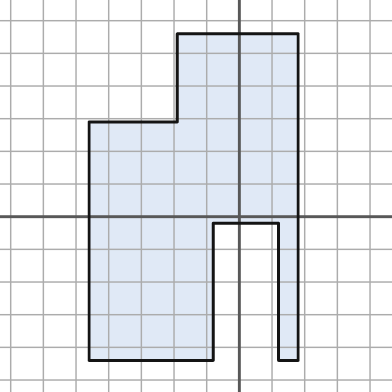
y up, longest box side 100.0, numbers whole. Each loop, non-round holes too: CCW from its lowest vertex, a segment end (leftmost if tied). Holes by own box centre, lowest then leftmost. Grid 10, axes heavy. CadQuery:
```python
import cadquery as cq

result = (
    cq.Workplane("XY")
    .moveTo(-46.0, -44.0)
    .lineTo(-8.0, -44.0)
    .lineTo(-8.0, -2.0)
    .lineTo(12.0, -2.0)
    .lineTo(12.0, -44.0)
    .lineTo(18.0, -44.0)
    .lineTo(18.0, 56.0)
    .lineTo(-19.0, 56.0)
    .lineTo(-19.0, 29.0)
    .lineTo(-46.0, 29.0)
    .close()
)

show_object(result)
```